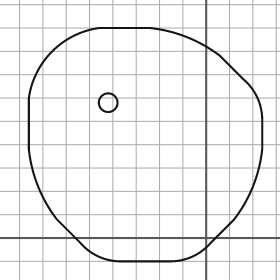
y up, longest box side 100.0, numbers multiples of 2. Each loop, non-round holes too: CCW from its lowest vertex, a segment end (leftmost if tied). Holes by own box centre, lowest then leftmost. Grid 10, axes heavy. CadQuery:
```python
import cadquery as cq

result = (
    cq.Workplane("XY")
    .moveTo(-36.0, -10.0)
    .lineTo(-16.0, -10.0)
    .threePointArc((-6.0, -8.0), (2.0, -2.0))
    .lineTo(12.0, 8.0)
    .threePointArc((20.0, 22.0), (24.0, 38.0))
    .lineTo(24.0, 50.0)
    .threePointArc((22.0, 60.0), (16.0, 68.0))
    .lineTo(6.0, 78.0)
    .threePointArc((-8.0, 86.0), (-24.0, 90.0))
    .lineTo(-46.0, 90.0)
    .threePointArc((-66.0, 80.0), (-76.0, 60.0))
    .lineTo(-76.0, 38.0)
    .threePointArc((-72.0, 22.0), (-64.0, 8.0))
    .lineTo(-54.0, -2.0)
    .threePointArc((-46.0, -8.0), (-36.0, -10.0))
    .close()
    .moveTo(-42.0, 58.0)
    .circle(4.0)
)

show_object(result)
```